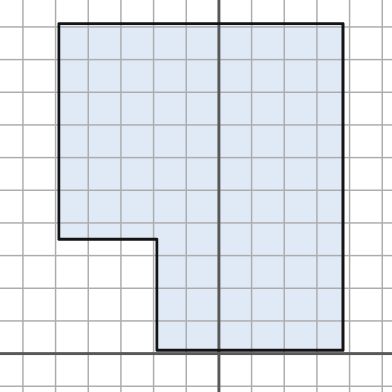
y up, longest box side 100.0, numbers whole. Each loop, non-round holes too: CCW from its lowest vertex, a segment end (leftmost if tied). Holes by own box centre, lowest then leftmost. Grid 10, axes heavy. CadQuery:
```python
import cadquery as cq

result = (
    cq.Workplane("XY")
    .moveTo(-19.0, 1.0)
    .lineTo(38.0, 1.0)
    .lineTo(38.0, 101.0)
    .lineTo(-49.0, 101.0)
    .lineTo(-49.0, 35.0)
    .lineTo(-19.0, 35.0)
    .close()
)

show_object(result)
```